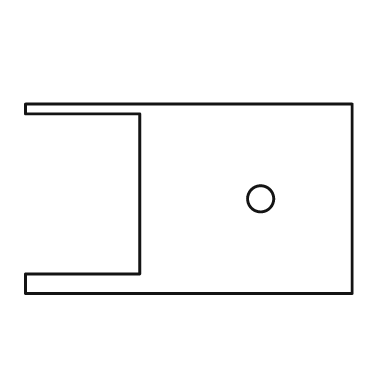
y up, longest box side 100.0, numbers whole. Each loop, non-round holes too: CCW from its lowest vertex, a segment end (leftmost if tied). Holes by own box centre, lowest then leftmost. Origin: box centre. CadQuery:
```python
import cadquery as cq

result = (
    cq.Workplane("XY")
    .moveTo(-50.0, -29.0)
    .lineTo(50.0, -29.0)
    .lineTo(50.0, 29.0)
    .lineTo(-50.0, 29.0)
    .lineTo(-50.0, 26.0)
    .lineTo(-15.0, 26.0)
    .lineTo(-15.0, -23.0)
    .lineTo(-50.0, -23.0)
    .close()
    .moveTo(22.0, 0.0)
    .circle(4.0)
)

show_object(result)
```